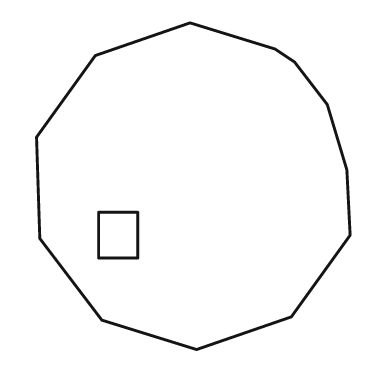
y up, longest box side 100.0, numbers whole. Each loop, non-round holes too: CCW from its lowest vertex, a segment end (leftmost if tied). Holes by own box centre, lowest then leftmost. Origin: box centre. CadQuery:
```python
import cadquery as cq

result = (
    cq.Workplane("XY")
    .moveTo(1.0, -50.0)
    .lineTo(30.0, -40.0)
    .lineTo(48.0, -15.0)
    .lineTo(47.0, 5.0)
    .lineTo(41.0, 25.0)
    .lineTo(31.0, 38.0)
    .lineTo(25.0, 42.0)
    .lineTo(-1.0, 50.0)
    .lineTo(-30.0, 40.0)
    .lineTo(-48.0, 15.0)
    .lineTo(-47.0, -16.0)
    .lineTo(-28.0, -41.0)
    .close()
    .moveTo(-29.0, -22.0)
    .lineTo(-17.0, -22.0)
    .lineTo(-17.0, -8.0)
    .lineTo(-29.0, -8.0)
    .close()
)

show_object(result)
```